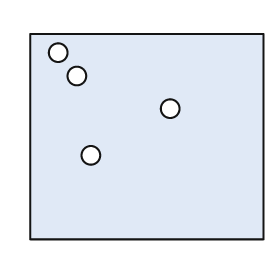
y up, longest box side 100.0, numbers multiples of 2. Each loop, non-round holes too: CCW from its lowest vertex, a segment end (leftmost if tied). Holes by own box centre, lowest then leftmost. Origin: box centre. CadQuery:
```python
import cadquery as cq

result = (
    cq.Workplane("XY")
    .moveTo(-50.0, -44.0)
    .lineTo(50.0, -44.0)
    .lineTo(50.0, 44.0)
    .lineTo(-50.0, 44.0)
    .close()
    .moveTo(-24.0, -8.0)
    .circle(4.0)
    .moveTo(10.0, 12.0)
    .circle(4.0)
    .moveTo(-30.0, 26.0)
    .circle(4.0)
    .moveTo(-38.0, 36.0)
    .circle(4.0)
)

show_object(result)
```